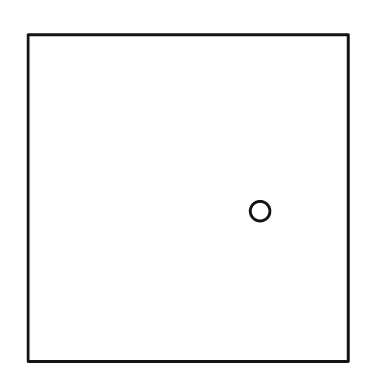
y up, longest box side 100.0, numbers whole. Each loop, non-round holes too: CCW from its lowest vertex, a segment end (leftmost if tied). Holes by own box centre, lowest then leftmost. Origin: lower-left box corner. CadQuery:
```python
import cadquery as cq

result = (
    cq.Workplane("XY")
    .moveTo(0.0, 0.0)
    .lineTo(98.0, 0.0)
    .lineTo(98.0, 100.0)
    .lineTo(0.0, 100.0)
    .close()
    .moveTo(71.0, 46.0)
    .circle(3.0)
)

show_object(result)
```